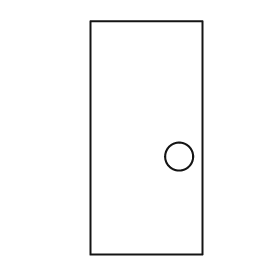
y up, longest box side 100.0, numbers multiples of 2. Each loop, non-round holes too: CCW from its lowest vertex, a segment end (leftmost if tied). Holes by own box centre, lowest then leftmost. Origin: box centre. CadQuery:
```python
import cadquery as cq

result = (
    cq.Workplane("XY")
    .moveTo(-24.0, -50.0)
    .lineTo(24.0, -50.0)
    .lineTo(24.0, 50.0)
    .lineTo(-24.0, 50.0)
    .close()
    .moveTo(14.0, -8.0)
    .circle(6.0)
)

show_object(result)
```